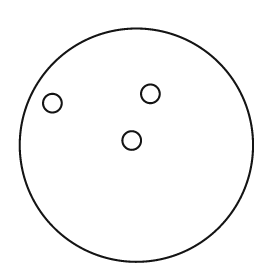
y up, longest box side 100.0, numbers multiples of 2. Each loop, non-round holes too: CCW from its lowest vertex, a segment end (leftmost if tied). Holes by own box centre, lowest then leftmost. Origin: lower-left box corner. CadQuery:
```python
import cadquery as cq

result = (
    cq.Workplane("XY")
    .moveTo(50.0, 50.0)
    .circle(50.0)
    .moveTo(48.0, 52.0)
    .circle(4.0)
    .moveTo(14.0, 68.0)
    .circle(4.0)
    .moveTo(56.0, 72.0)
    .circle(4.0)
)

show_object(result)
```